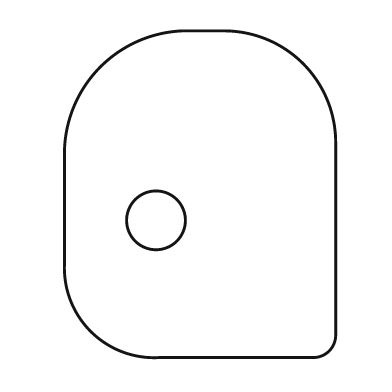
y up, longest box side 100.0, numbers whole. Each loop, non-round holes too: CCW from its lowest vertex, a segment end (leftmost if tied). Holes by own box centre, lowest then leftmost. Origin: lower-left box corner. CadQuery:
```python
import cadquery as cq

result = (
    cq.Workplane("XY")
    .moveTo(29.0, 0.0)
    .lineTo(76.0, 0.0)
    .threePointArc((81.0, 2.0), (83.0, 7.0))
    .lineTo(83.0, 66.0)
    .threePointArc((73.0, 90.0), (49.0, 100.0))
    .lineTo(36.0, 100.0)
    .threePointArc((11.0, 89.0), (0.0, 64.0))
    .lineTo(0.0, 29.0)
    .threePointArc((8.0, 8.0), (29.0, 0.0))
    .close()
    .moveTo(28.0, 42.0)
    .circle(9.0)
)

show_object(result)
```